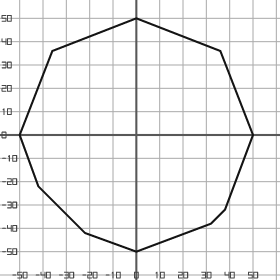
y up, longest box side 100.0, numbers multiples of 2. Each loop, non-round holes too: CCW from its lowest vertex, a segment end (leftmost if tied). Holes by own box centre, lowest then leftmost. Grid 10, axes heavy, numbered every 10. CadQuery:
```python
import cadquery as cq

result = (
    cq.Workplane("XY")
    .moveTo(0.0, -50.0)
    .lineTo(32.0, -38.0)
    .lineTo(38.0, -32.0)
    .lineTo(50.0, 0.0)
    .lineTo(36.0, 36.0)
    .lineTo(0.0, 50.0)
    .lineTo(-36.0, 36.0)
    .lineTo(-50.0, 0.0)
    .lineTo(-42.0, -22.0)
    .lineTo(-22.0, -42.0)
    .close()
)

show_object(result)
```